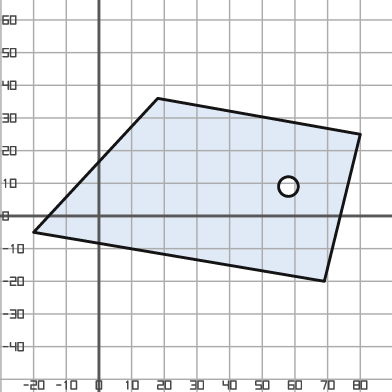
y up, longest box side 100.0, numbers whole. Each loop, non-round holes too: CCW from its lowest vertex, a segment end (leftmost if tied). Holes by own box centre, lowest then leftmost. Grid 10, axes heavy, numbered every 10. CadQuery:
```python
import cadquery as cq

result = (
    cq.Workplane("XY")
    .moveTo(69.0, -20.0)
    .lineTo(80.0, 25.0)
    .lineTo(18.0, 36.0)
    .lineTo(-20.0, -5.0)
    .close()
    .moveTo(58.0, 9.0)
    .circle(3.0)
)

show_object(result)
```